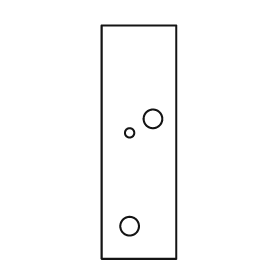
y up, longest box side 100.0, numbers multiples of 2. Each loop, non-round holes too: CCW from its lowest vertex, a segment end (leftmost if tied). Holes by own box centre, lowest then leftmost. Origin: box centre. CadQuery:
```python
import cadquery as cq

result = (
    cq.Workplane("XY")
    .moveTo(-16.0, -50.0)
    .lineTo(16.0, -50.0)
    .lineTo(16.0, 50.0)
    .lineTo(-16.0, 50.0)
    .close()
    .moveTo(-4.0, -36.0)
    .circle(4.0)
    .moveTo(-4.0, 4.0)
    .circle(2.0)
    .moveTo(6.0, 10.0)
    .circle(4.0)
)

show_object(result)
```